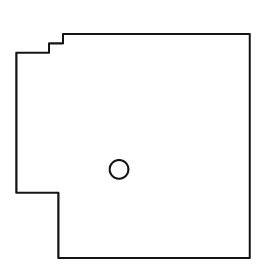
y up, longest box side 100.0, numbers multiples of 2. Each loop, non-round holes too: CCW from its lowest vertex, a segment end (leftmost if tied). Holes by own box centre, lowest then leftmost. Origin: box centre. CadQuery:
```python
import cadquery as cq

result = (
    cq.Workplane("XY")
    .moveTo(-32.0, -48.0)
    .lineTo(50.0, -48.0)
    .lineTo(50.0, 48.0)
    .lineTo(-30.0, 48.0)
    .lineTo(-30.0, 44.0)
    .lineTo(-36.0, 44.0)
    .lineTo(-36.0, 40.0)
    .lineTo(-50.0, 40.0)
    .lineTo(-50.0, -20.0)
    .lineTo(-32.0, -20.0)
    .close()
    .moveTo(-6.0, -10.0)
    .circle(4.0)
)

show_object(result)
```